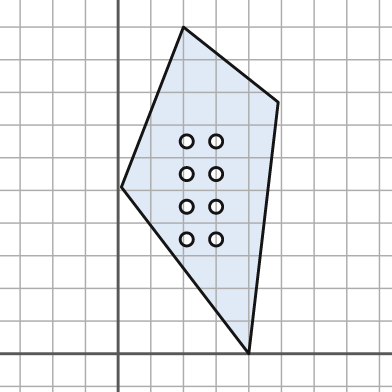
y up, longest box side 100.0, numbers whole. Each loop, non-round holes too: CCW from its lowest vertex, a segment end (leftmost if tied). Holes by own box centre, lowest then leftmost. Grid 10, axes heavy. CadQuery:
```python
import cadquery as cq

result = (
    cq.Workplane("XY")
    .moveTo(40.0, 0.0)
    .lineTo(49.0, 77.0)
    .lineTo(20.0, 100.0)
    .lineTo(1.0, 51.0)
    .close()
    .moveTo(21.0, 35.0)
    .circle(2.0)
    .moveTo(30.0, 35.0)
    .circle(2.0)
    .moveTo(21.0, 45.0)
    .circle(2.0)
    .moveTo(30.0, 45.0)
    .circle(2.0)
    .moveTo(21.0, 55.0)
    .circle(2.0)
    .moveTo(30.0, 55.0)
    .circle(2.0)
    .moveTo(21.0, 65.0)
    .circle(2.0)
    .moveTo(30.0, 65.0)
    .circle(2.0)
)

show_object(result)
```